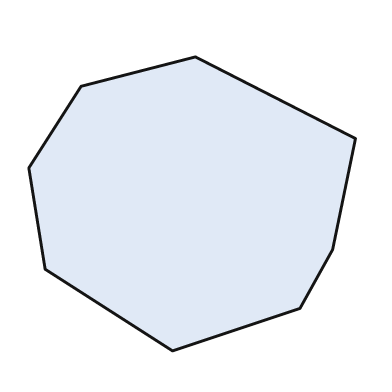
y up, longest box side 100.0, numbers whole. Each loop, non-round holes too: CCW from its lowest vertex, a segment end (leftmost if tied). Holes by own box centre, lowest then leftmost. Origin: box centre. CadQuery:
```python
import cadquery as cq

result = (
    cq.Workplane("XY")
    .moveTo(-6.0, -45.0)
    .lineTo(33.0, -32.0)
    .lineTo(43.0, -14.0)
    .lineTo(50.0, 20.0)
    .lineTo(1.0, 45.0)
    .lineTo(-34.0, 36.0)
    .lineTo(-50.0, 11.0)
    .lineTo(-45.0, -20.0)
    .close()
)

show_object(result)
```